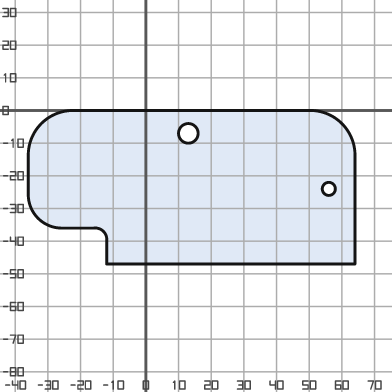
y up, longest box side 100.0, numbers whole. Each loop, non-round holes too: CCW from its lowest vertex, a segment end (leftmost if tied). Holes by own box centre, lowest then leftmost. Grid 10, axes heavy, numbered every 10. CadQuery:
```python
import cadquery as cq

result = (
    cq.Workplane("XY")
    .moveTo(-12.0, -47.0)
    .lineTo(64.0, -47.0)
    .lineTo(64.0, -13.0)
    .threePointArc((60.0, -4.0), (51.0, 0.0))
    .lineTo(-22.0, 0.0)
    .threePointArc((-32.0, -4.0), (-36.0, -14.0))
    .lineTo(-36.0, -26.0)
    .threePointArc((-33.0, -33.0), (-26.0, -36.0))
    .lineTo(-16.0, -36.0)
    .threePointArc((-13.0, -37.0), (-12.0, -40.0))
    .close()
    .moveTo(56.0, -24.0)
    .circle(2.0)
    .moveTo(13.0, -7.0)
    .circle(3.0)
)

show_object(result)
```